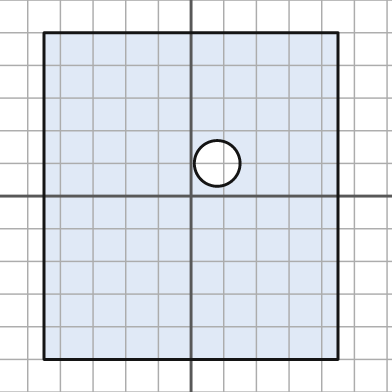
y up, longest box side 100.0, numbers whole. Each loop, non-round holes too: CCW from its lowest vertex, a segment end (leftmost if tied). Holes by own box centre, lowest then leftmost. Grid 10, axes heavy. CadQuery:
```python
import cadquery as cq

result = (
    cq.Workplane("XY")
    .moveTo(-45.0, -50.0)
    .lineTo(45.0, -50.0)
    .lineTo(45.0, 50.0)
    .lineTo(-45.0, 50.0)
    .close()
    .moveTo(8.0, 10.0)
    .circle(7.0)
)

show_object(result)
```